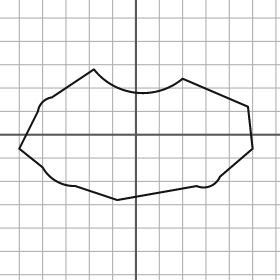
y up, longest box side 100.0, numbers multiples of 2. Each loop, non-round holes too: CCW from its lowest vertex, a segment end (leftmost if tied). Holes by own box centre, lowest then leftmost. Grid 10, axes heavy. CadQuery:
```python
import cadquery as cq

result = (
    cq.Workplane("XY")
    .moveTo(-8.0, -28.0)
    .lineTo(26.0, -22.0)
    .threePointArc((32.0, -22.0), (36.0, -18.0))
    .lineTo(50.0, -6.0)
    .lineTo(48.0, 12.0)
    .lineTo(20.0, 24.0)
    .threePointArc((0.0, 18.0), (-18.0, 28.0))
    .lineTo(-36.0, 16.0)
    .threePointArc((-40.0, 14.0), (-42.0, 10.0))
    .lineTo(-50.0, -6.0)
    .lineTo(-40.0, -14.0)
    .threePointArc((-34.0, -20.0), (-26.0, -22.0))
    .close()
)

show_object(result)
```